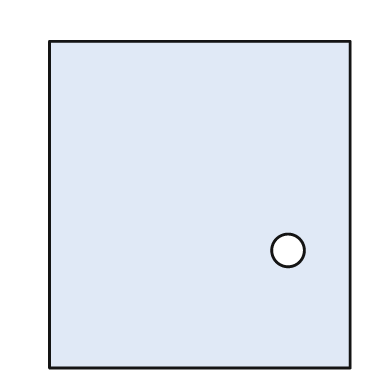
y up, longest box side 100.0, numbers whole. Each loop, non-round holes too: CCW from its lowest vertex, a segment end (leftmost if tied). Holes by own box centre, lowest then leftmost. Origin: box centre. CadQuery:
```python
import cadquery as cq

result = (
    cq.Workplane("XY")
    .moveTo(-46.0, -50.0)
    .lineTo(46.0, -50.0)
    .lineTo(46.0, 50.0)
    .lineTo(-46.0, 50.0)
    .close()
    .moveTo(27.0, -14.0)
    .circle(5.0)
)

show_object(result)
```